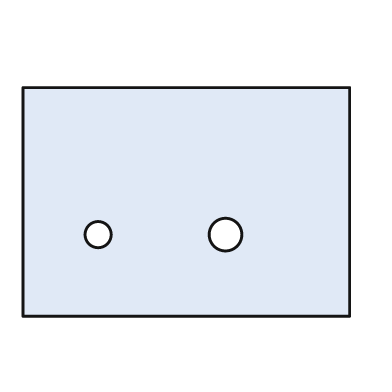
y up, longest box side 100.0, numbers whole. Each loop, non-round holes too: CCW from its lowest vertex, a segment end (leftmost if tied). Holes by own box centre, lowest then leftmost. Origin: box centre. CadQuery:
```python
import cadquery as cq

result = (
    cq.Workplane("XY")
    .moveTo(-50.0, -35.0)
    .lineTo(50.0, -35.0)
    .lineTo(50.0, 35.0)
    .lineTo(-50.0, 35.0)
    .close()
    .moveTo(-27.0, -10.0)
    .circle(4.0)
    .moveTo(12.0, -10.0)
    .circle(5.0)
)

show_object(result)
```